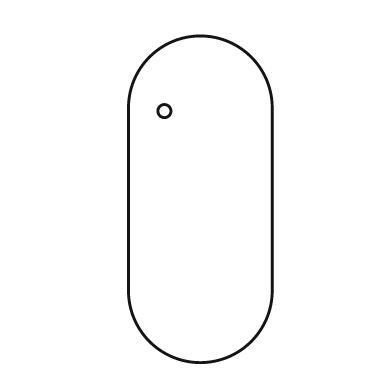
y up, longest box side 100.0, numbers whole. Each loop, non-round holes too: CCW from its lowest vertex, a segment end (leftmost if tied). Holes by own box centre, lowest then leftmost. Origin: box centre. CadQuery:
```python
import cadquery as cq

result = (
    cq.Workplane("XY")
    .moveTo(-22.0, -28.0)
    .threePointArc((0.0, -50.0), (22.0, -28.0))
    .lineTo(22.0, 28.0)
    .threePointArc((0.0, 50.0), (-22.0, 28.0))
    .close()
    .moveTo(-11.0, 27.0)
    .circle(2.0)
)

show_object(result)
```